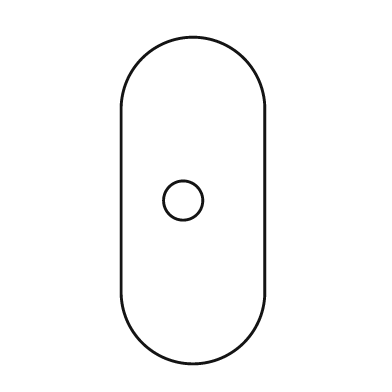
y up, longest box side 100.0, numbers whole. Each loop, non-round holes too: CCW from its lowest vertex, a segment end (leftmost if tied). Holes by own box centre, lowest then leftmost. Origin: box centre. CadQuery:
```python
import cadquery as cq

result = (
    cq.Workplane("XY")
    .moveTo(-22.0, -28.0)
    .threePointArc((0.0, -50.0), (22.0, -28.0))
    .lineTo(22.0, 28.0)
    .threePointArc((0.0, 50.0), (-22.0, 28.0))
    .close()
    .moveTo(-3.0, 0.0)
    .circle(6.0)
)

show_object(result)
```